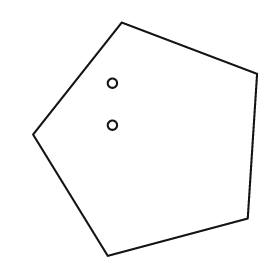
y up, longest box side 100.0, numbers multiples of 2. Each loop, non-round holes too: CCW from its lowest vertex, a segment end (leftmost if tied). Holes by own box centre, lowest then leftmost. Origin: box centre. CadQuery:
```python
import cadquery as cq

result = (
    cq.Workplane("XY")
    .moveTo(-16.0, -50.0)
    .lineTo(44.0, -34.0)
    .lineTo(48.0, 28.0)
    .lineTo(-10.0, 50.0)
    .lineTo(-48.0, 2.0)
    .close()
    .moveTo(-14.0, 6.0)
    .circle(2.0)
    .moveTo(-14.0, 24.0)
    .circle(2.0)
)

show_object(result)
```